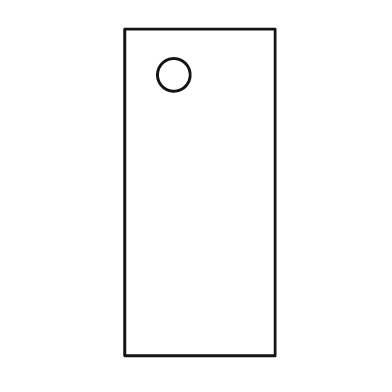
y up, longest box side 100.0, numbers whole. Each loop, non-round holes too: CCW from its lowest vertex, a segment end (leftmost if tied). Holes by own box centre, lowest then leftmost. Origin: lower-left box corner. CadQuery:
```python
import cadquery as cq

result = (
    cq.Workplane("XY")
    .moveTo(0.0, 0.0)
    .lineTo(46.0, 0.0)
    .lineTo(46.0, 100.0)
    .lineTo(0.0, 100.0)
    .close()
    .moveTo(15.0, 86.0)
    .circle(5.0)
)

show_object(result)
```